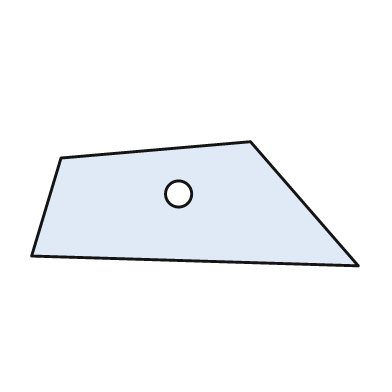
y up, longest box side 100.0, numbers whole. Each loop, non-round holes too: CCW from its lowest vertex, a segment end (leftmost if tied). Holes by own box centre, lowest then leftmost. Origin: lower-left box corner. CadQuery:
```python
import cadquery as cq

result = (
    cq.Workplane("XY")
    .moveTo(100.0, 0.0)
    .lineTo(67.0, 38.0)
    .lineTo(9.0, 33.0)
    .lineTo(0.0, 3.0)
    .close()
    .moveTo(45.0, 22.0)
    .circle(4.0)
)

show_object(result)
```